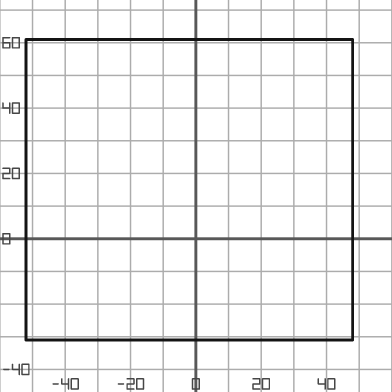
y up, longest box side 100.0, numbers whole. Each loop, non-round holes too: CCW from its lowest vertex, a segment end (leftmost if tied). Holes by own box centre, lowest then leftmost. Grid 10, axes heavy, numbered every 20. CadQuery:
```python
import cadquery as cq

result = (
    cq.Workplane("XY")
    .moveTo(-52.0, -31.0)
    .lineTo(48.0, -31.0)
    .lineTo(48.0, 61.0)
    .lineTo(-52.0, 61.0)
    .close()
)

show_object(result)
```